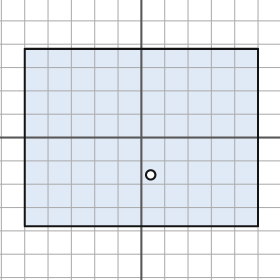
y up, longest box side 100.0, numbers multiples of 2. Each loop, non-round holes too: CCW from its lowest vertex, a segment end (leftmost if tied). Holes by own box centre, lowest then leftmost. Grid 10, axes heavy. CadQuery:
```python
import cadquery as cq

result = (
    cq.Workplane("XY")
    .moveTo(-50.0, -38.0)
    .lineTo(50.0, -38.0)
    .lineTo(50.0, 38.0)
    .lineTo(-50.0, 38.0)
    .close()
    .moveTo(4.0, -16.0)
    .circle(2.0)
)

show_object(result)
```